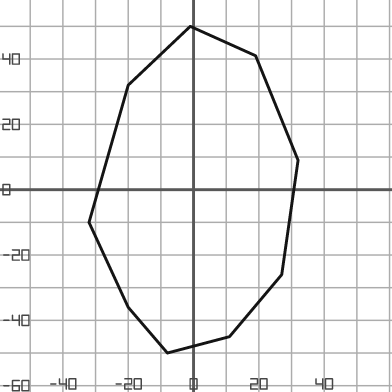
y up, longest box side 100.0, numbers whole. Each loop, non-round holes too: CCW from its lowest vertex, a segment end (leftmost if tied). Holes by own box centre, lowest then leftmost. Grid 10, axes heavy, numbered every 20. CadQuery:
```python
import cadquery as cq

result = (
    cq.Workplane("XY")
    .moveTo(-8.0, -50.0)
    .lineTo(11.0, -45.0)
    .lineTo(27.0, -26.0)
    .lineTo(32.0, 9.0)
    .lineTo(19.0, 41.0)
    .lineTo(-1.0, 50.0)
    .lineTo(-20.0, 32.0)
    .lineTo(-32.0, -10.0)
    .lineTo(-20.0, -36.0)
    .close()
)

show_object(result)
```